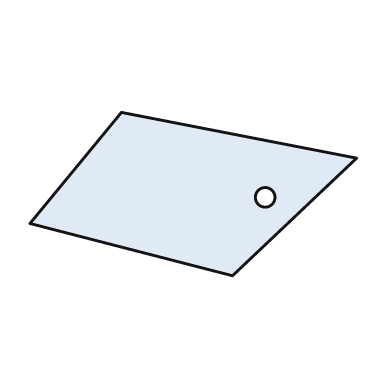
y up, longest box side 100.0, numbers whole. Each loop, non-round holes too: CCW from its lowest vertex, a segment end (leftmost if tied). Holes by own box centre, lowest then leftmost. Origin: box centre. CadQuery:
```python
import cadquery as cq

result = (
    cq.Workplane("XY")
    .moveTo(12.0, -25.0)
    .lineTo(50.0, 11.0)
    .lineTo(-22.0, 25.0)
    .lineTo(-50.0, -9.0)
    .close()
    .moveTo(22.0, -1.0)
    .circle(3.0)
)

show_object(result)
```